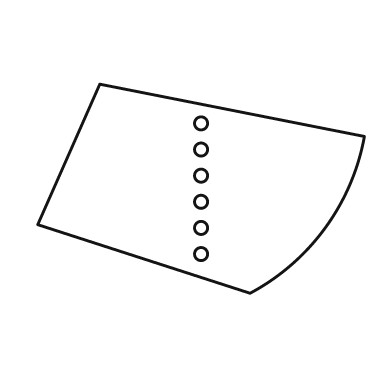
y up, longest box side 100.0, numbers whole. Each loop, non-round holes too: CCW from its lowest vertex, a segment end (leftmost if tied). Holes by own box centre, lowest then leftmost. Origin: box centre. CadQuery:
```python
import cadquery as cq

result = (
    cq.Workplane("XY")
    .moveTo(15.0, -32.0)
    .threePointArc((38.0, -12.0), (50.0, 16.0))
    .lineTo(-31.0, 32.0)
    .lineTo(-50.0, -11.0)
    .close()
    .moveTo(0.0, -20.0)
    .circle(2.0)
    .moveTo(0.0, -12.0)
    .circle(2.0)
    .moveTo(0.0, -4.0)
    .circle(2.0)
    .moveTo(0.0, 4.0)
    .circle(2.0)
    .moveTo(0.0, 12.0)
    .circle(2.0)
    .moveTo(0.0, 20.0)
    .circle(2.0)
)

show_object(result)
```